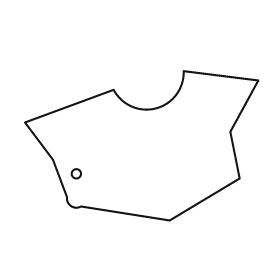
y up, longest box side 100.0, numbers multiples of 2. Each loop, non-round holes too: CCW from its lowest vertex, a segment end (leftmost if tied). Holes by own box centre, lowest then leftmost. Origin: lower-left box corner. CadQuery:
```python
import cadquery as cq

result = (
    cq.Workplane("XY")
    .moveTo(62.0, 0.0)
    .lineTo(92.0, 18.0)
    .lineTo(88.0, 38.0)
    .lineTo(100.0, 60.0)
    .lineTo(68.0, 64.0)
    .threePointArc((56.0, 48.0), (38.0, 56.0))
    .lineTo(0.0, 42.0)
    .lineTo(12.0, 26.0)
    .lineTo(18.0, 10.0)
    .threePointArc((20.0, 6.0), (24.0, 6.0))
    .close()
    .moveTo(22.0, 20.0)
    .circle(2.0)
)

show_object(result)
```